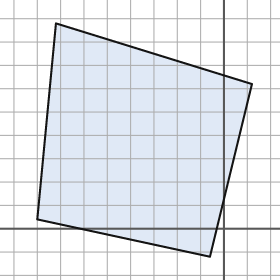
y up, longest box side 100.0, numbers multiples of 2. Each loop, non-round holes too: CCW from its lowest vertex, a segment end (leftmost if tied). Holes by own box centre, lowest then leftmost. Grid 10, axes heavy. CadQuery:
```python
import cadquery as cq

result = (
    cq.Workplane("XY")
    .moveTo(-6.0, -12.0)
    .lineTo(12.0, 62.0)
    .lineTo(-72.0, 88.0)
    .lineTo(-80.0, 4.0)
    .close()
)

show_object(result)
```